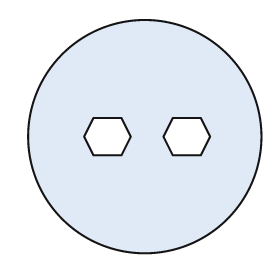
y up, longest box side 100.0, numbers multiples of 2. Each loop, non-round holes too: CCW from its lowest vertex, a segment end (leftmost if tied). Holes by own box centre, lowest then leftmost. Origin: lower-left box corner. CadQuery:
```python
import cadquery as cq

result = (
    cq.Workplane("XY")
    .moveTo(50.0, 50.0)
    .circle(50.0)
    .moveTo(28.0, 42.0)
    .lineTo(40.0, 42.0)
    .lineTo(44.0, 50.0)
    .lineTo(40.0, 58.0)
    .lineTo(28.0, 58.0)
    .lineTo(24.0, 50.0)
    .close()
    .moveTo(62.0, 42.0)
    .lineTo(74.0, 42.0)
    .lineTo(78.0, 50.0)
    .lineTo(74.0, 58.0)
    .lineTo(62.0, 58.0)
    .lineTo(58.0, 50.0)
    .close()
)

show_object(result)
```